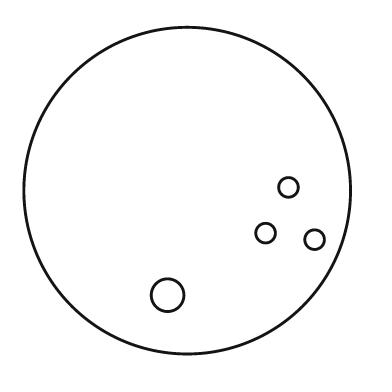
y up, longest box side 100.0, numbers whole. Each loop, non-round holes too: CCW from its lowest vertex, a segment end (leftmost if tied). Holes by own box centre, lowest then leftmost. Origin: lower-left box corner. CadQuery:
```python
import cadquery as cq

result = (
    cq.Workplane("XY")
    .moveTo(50.0, 50.0)
    .circle(50.0)
    .moveTo(44.0, 18.0)
    .circle(5.0)
    .moveTo(89.0, 35.0)
    .circle(3.0)
    .moveTo(74.0, 37.0)
    .circle(3.0)
    .moveTo(81.0, 51.0)
    .circle(3.0)
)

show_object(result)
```